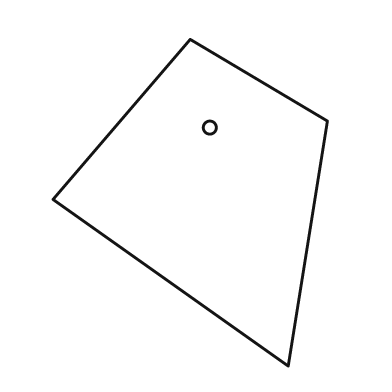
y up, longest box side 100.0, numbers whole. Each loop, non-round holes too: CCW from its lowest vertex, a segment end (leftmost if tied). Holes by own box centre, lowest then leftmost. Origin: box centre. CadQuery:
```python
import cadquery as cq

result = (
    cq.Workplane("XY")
    .moveTo(30.0, -50.0)
    .lineTo(42.0, 25.0)
    .lineTo(0.0, 50.0)
    .lineTo(-42.0, 1.0)
    .close()
    .moveTo(6.0, 23.0)
    .circle(2.0)
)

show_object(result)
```